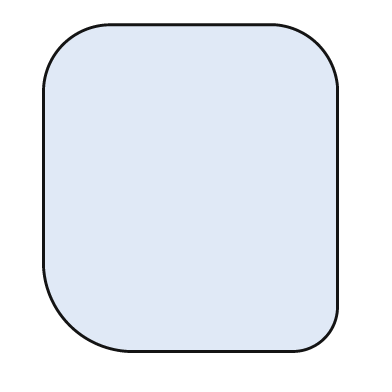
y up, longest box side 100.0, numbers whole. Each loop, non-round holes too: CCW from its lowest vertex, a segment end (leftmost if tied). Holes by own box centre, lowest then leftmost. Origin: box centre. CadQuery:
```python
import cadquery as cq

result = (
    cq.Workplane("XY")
    .moveTo(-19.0, -50.0)
    .lineTo(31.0, -50.0)
    .threePointArc((41.0, -46.0), (45.0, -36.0))
    .lineTo(45.0, 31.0)
    .threePointArc((39.0, 44.0), (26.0, 50.0))
    .lineTo(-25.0, 50.0)
    .threePointArc((-39.0, 44.0), (-45.0, 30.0))
    .lineTo(-45.0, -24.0)
    .threePointArc((-37.0, -42.0), (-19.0, -50.0))
    .close()
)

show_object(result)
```